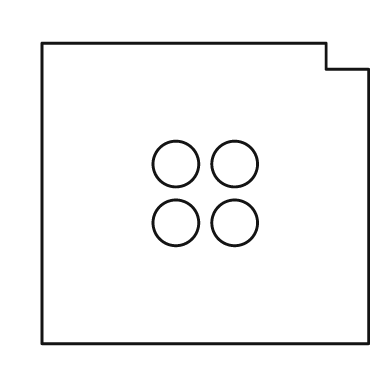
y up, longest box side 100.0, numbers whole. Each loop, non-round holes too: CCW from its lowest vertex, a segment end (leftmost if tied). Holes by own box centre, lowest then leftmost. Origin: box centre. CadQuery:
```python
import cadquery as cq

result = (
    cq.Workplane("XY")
    .moveTo(-50.0, -46.0)
    .lineTo(50.0, -46.0)
    .lineTo(50.0, 38.0)
    .lineTo(37.0, 38.0)
    .lineTo(37.0, 46.0)
    .lineTo(-50.0, 46.0)
    .close()
    .moveTo(-9.0, -9.0)
    .circle(7.0)
    .moveTo(9.0, -9.0)
    .circle(7.0)
    .moveTo(-9.0, 9.0)
    .circle(7.0)
    .moveTo(9.0, 9.0)
    .circle(7.0)
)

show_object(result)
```